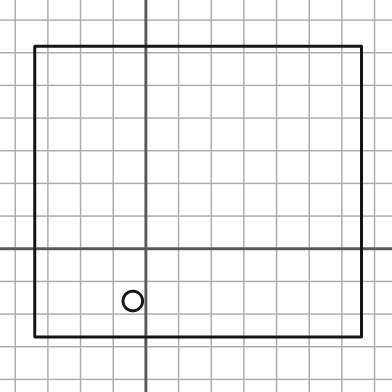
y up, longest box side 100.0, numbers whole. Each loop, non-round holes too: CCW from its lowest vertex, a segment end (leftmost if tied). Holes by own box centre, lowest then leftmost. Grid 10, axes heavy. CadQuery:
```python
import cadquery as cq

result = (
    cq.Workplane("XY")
    .moveTo(-34.0, -27.0)
    .lineTo(66.0, -27.0)
    .lineTo(66.0, 62.0)
    .lineTo(-34.0, 62.0)
    .close()
    .moveTo(-4.0, -16.0)
    .circle(3.0)
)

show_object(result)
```